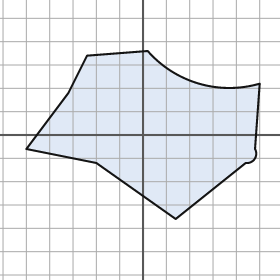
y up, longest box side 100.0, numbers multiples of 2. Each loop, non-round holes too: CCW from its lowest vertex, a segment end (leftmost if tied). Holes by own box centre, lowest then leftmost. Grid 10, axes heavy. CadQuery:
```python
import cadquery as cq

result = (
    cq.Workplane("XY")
    .moveTo(14.0, -36.0)
    .lineTo(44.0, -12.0)
    .threePointArc((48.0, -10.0), (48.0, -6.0))
    .lineTo(50.0, 22.0)
    .threePointArc((24.0, 22.0), (2.0, 36.0))
    .lineTo(-24.0, 34.0)
    .lineTo(-32.0, 18.0)
    .lineTo(-50.0, -6.0)
    .lineTo(-20.0, -12.0)
    .close()
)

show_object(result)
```